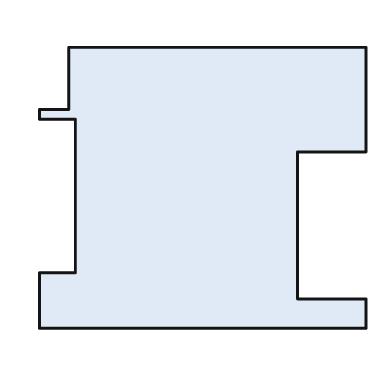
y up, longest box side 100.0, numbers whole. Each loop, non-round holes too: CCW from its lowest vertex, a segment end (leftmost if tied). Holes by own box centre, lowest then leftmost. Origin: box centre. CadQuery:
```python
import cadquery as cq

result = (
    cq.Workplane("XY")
    .moveTo(-50.0, -43.0)
    .lineTo(50.0, -43.0)
    .lineTo(50.0, -34.0)
    .lineTo(29.0, -34.0)
    .lineTo(29.0, 11.0)
    .lineTo(50.0, 11.0)
    .lineTo(50.0, 43.0)
    .lineTo(-41.0, 43.0)
    .lineTo(-41.0, 24.0)
    .lineTo(-50.0, 24.0)
    .lineTo(-50.0, 21.0)
    .lineTo(-39.0, 21.0)
    .lineTo(-39.0, -26.0)
    .lineTo(-50.0, -26.0)
    .close()
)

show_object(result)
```